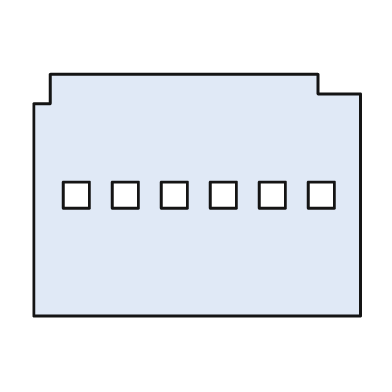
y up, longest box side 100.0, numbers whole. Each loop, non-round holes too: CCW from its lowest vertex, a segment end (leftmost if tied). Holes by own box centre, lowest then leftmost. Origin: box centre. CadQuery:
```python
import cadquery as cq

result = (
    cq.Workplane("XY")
    .moveTo(-50.0, -37.0)
    .lineTo(50.0, -37.0)
    .lineTo(50.0, 31.0)
    .lineTo(37.0, 31.0)
    .lineTo(37.0, 37.0)
    .lineTo(-45.0, 37.0)
    .lineTo(-45.0, 28.0)
    .lineTo(-50.0, 28.0)
    .close()
    .moveTo(-41.0, -4.0)
    .lineTo(-33.0, -4.0)
    .lineTo(-33.0, 4.0)
    .lineTo(-41.0, 4.0)
    .close()
    .moveTo(-26.0, -4.0)
    .lineTo(-18.0, -4.0)
    .lineTo(-18.0, 4.0)
    .lineTo(-26.0, 4.0)
    .close()
    .moveTo(-11.0, -4.0)
    .lineTo(-3.0, -4.0)
    .lineTo(-3.0, 4.0)
    .lineTo(-11.0, 4.0)
    .close()
    .moveTo(4.0, -4.0)
    .lineTo(12.0, -4.0)
    .lineTo(12.0, 4.0)
    .lineTo(4.0, 4.0)
    .close()
    .moveTo(19.0, -4.0)
    .lineTo(27.0, -4.0)
    .lineTo(27.0, 4.0)
    .lineTo(19.0, 4.0)
    .close()
    .moveTo(34.0, -4.0)
    .lineTo(42.0, -4.0)
    .lineTo(42.0, 4.0)
    .lineTo(34.0, 4.0)
    .close()
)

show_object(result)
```